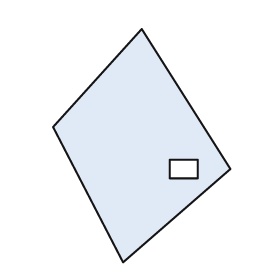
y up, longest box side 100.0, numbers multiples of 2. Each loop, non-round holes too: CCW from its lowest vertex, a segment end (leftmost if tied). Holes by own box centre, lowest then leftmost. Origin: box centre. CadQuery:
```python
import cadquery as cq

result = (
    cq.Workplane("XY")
    .moveTo(-8.0, -50.0)
    .lineTo(38.0, -10.0)
    .lineTo(0.0, 50.0)
    .lineTo(-38.0, 8.0)
    .close()
    .moveTo(12.0, -14.0)
    .lineTo(24.0, -14.0)
    .lineTo(24.0, -6.0)
    .lineTo(12.0, -6.0)
    .close()
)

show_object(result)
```